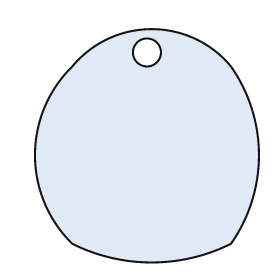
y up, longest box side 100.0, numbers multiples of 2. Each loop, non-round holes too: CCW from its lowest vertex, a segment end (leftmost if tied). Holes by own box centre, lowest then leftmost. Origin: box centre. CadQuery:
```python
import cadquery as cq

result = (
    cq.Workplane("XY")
    .moveTo(-32.0, -42.0)
    .threePointArc((2.0, -50.0), (36.0, -42.0))
    .threePointArc((48.0, -4.0), (36.0, 34.0))
    .threePointArc((2.0, 50.0), (-32.0, 34.0))
    .threePointArc((-48.0, -4.0), (-32.0, -42.0))
    .close()
    .moveTo(0.0, 40.0)
    .circle(6.0)
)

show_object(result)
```